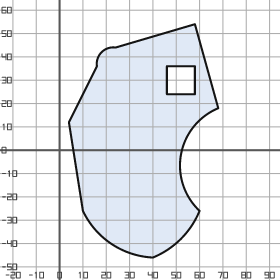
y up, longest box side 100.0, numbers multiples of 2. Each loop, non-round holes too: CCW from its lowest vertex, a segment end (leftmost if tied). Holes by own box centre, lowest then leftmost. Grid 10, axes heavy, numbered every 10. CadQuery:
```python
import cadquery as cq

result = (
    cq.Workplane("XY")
    .moveTo(40.0, -46.0)
    .threePointArc((52.0, -38.0), (60.0, -26.0))
    .threePointArc((52.0, -2.0), (68.0, 18.0))
    .lineTo(58.0, 54.0)
    .lineTo(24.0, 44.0)
    .threePointArc((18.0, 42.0), (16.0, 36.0))
    .lineTo(4.0, 12.0)
    .lineTo(10.0, -26.0)
    .threePointArc((22.0, -40.0), (40.0, -46.0))
    .close()
    .moveTo(46.0, 24.0)
    .lineTo(58.0, 24.0)
    .lineTo(58.0, 36.0)
    .lineTo(46.0, 36.0)
    .close()
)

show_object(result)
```